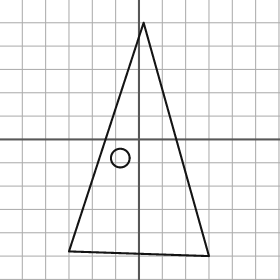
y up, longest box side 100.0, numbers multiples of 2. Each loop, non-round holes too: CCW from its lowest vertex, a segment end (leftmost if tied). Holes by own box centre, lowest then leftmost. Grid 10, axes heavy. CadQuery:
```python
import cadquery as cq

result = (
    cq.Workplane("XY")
    .moveTo(30.0, -50.0)
    .lineTo(2.0, 50.0)
    .lineTo(-30.0, -48.0)
    .close()
    .moveTo(-8.0, -8.0)
    .circle(4.0)
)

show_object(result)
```